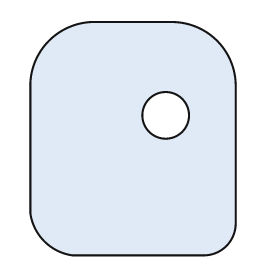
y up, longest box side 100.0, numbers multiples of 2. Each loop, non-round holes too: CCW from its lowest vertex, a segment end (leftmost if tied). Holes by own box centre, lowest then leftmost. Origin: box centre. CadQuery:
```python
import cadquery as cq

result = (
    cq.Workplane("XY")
    .moveTo(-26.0, -50.0)
    .lineTo(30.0, -50.0)
    .threePointArc((40.0, -46.0), (44.0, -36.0))
    .lineTo(44.0, 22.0)
    .threePointArc((36.0, 42.0), (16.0, 50.0))
    .lineTo(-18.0, 50.0)
    .threePointArc((-36.0, 42.0), (-44.0, 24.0))
    .lineTo(-44.0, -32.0)
    .threePointArc((-38.0, -44.0), (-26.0, -50.0))
    .close()
    .moveTo(14.0, 10.0)
    .circle(10.0)
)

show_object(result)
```